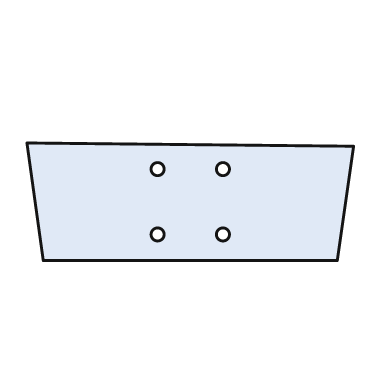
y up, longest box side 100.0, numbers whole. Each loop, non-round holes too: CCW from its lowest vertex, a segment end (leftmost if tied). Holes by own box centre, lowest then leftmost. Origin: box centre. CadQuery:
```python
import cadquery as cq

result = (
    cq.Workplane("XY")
    .moveTo(-45.0, -18.0)
    .lineTo(45.0, -18.0)
    .lineTo(50.0, 17.0)
    .lineTo(-50.0, 18.0)
    .close()
    .moveTo(-10.0, -10.0)
    .circle(2.0)
    .moveTo(10.0, -10.0)
    .circle(2.0)
    .moveTo(-10.0, 10.0)
    .circle(2.0)
    .moveTo(10.0, 10.0)
    .circle(2.0)
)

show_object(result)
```